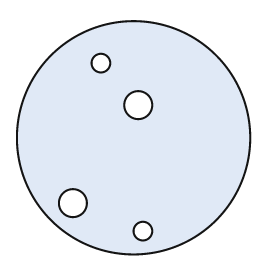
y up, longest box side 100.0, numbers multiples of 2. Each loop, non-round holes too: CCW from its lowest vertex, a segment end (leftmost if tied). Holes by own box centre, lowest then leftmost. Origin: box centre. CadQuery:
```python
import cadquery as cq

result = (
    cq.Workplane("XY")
    .moveTo(0.0, 0.0)
    .circle(50.0)
    .moveTo(4.0, -40.0)
    .circle(4.0)
    .moveTo(-26.0, -28.0)
    .circle(6.0)
    .moveTo(2.0, 14.0)
    .circle(6.0)
    .moveTo(-14.0, 32.0)
    .circle(4.0)
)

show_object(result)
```